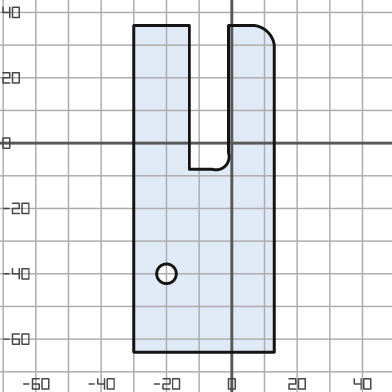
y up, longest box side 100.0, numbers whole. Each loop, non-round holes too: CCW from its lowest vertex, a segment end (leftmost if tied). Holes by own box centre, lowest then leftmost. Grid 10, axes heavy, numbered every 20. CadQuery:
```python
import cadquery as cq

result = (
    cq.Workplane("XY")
    .moveTo(-30.0, -64.0)
    .lineTo(13.0, -64.0)
    .lineTo(13.0, 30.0)
    .threePointArc((11.0, 34.0), (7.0, 36.0))
    .lineTo(-1.0, 36.0)
    .lineTo(-1.0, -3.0)
    .threePointArc((-2.0, -7.0), (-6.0, -8.0))
    .lineTo(-13.0, -8.0)
    .lineTo(-13.0, 36.0)
    .lineTo(-30.0, 36.0)
    .close()
    .moveTo(-20.0, -40.0)
    .circle(3.0)
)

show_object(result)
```